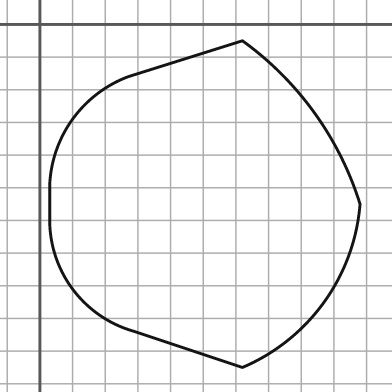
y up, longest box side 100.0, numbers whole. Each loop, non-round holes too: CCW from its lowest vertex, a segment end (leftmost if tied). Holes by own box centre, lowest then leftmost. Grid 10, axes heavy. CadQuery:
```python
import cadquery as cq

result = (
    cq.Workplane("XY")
    .moveTo(62.0, -105.0)
    .threePointArc((87.0, -85.0), (98.0, -55.0))
    .threePointArc((84.0, -27.0), (62.0, -5.0))
    .lineTo(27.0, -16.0)
    .threePointArc((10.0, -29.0), (3.0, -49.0))
    .lineTo(3.0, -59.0)
    .threePointArc((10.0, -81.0), (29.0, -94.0))
    .close()
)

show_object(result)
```